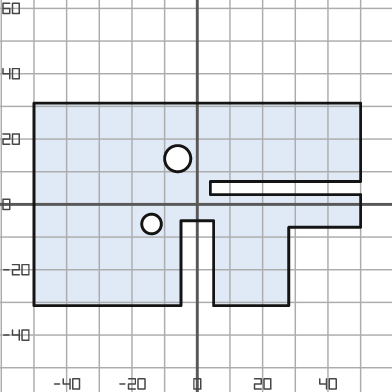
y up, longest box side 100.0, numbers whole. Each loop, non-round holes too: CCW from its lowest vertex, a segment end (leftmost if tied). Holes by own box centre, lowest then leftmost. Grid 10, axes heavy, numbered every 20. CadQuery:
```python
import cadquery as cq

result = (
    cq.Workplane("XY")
    .moveTo(-50.0, -31.0)
    .lineTo(-5.0, -31.0)
    .lineTo(-5.0, -5.0)
    .lineTo(5.0, -5.0)
    .lineTo(5.0, -31.0)
    .lineTo(28.0, -31.0)
    .lineTo(28.0, -7.0)
    .lineTo(50.0, -7.0)
    .lineTo(50.0, 3.0)
    .lineTo(4.0, 3.0)
    .lineTo(4.0, 7.0)
    .lineTo(50.0, 7.0)
    .lineTo(50.0, 31.0)
    .lineTo(-50.0, 31.0)
    .close()
    .moveTo(-14.0, -6.0)
    .circle(3.0)
    .moveTo(-6.0, 14.0)
    .circle(4.0)
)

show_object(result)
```